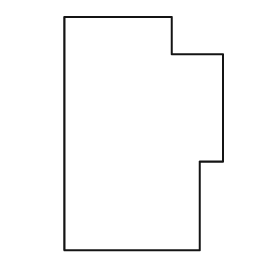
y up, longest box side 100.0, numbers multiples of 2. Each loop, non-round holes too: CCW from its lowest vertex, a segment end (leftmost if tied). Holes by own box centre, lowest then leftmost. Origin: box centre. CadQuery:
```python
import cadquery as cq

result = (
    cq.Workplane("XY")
    .moveTo(-34.0, -50.0)
    .lineTo(24.0, -50.0)
    .lineTo(24.0, -12.0)
    .lineTo(34.0, -12.0)
    .lineTo(34.0, 34.0)
    .lineTo(12.0, 34.0)
    .lineTo(12.0, 50.0)
    .lineTo(-34.0, 50.0)
    .close()
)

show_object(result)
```